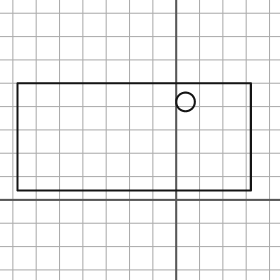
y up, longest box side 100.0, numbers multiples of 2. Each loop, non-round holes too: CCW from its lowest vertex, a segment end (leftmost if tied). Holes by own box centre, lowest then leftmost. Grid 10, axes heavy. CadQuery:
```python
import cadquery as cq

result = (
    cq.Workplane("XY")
    .moveTo(-68.0, 4.0)
    .lineTo(32.0, 4.0)
    .lineTo(32.0, 50.0)
    .lineTo(-68.0, 50.0)
    .close()
    .moveTo(4.0, 42.0)
    .circle(4.0)
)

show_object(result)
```